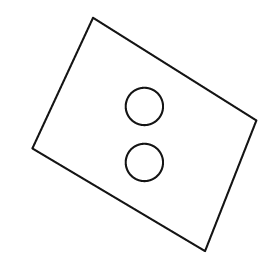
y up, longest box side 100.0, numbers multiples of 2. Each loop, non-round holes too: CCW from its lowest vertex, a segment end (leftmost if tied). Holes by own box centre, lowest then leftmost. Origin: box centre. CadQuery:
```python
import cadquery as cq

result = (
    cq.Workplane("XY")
    .moveTo(26.0, -50.0)
    .lineTo(48.0, 6.0)
    .lineTo(-22.0, 50.0)
    .lineTo(-48.0, -6.0)
    .close()
    .moveTo(0.0, -12.0)
    .circle(8.0)
    .moveTo(0.0, 12.0)
    .circle(8.0)
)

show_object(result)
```